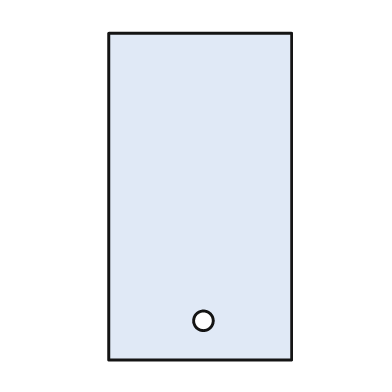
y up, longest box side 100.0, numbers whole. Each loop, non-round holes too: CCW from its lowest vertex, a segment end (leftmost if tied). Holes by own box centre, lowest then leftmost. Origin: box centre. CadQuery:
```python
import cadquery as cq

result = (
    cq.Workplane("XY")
    .moveTo(-28.0, -50.0)
    .lineTo(28.0, -50.0)
    .lineTo(28.0, 50.0)
    .lineTo(-28.0, 50.0)
    .close()
    .moveTo(1.0, -38.0)
    .circle(3.0)
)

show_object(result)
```